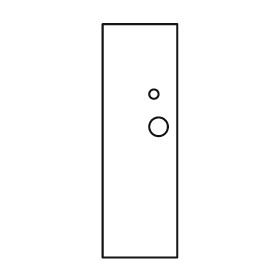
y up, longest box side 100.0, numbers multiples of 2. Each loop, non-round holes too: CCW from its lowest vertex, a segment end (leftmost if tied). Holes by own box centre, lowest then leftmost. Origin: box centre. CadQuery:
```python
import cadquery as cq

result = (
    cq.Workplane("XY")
    .moveTo(-16.0, -50.0)
    .lineTo(16.0, -50.0)
    .lineTo(16.0, 50.0)
    .lineTo(-16.0, 50.0)
    .close()
    .moveTo(8.0, 6.0)
    .circle(4.0)
    .moveTo(6.0, 20.0)
    .circle(2.0)
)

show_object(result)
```